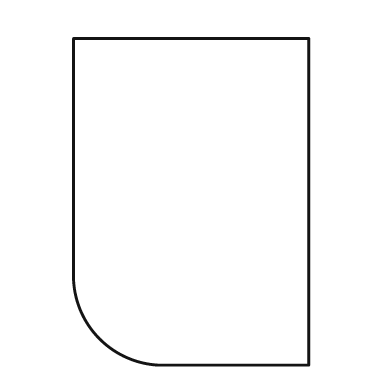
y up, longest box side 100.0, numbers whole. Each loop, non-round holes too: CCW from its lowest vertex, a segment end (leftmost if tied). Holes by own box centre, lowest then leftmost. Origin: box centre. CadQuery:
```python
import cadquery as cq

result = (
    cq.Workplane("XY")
    .moveTo(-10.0, -50.0)
    .lineTo(36.0, -50.0)
    .lineTo(36.0, 50.0)
    .lineTo(-36.0, 50.0)
    .lineTo(-36.0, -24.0)
    .threePointArc((-28.0, -42.0), (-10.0, -50.0))
    .close()
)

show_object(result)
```